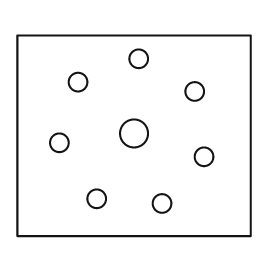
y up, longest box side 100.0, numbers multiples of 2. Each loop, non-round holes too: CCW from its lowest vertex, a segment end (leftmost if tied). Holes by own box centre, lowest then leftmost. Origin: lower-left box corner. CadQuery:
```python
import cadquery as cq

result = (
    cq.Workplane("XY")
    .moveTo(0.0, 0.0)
    .lineTo(100.0, 0.0)
    .lineTo(100.0, 86.0)
    .lineTo(0.0, 86.0)
    .close()
    .moveTo(62.0, 14.0)
    .circle(4.0)
    .moveTo(34.0, 16.0)
    .circle(4.0)
    .moveTo(80.0, 34.0)
    .circle(4.0)
    .moveTo(18.0, 40.0)
    .circle(4.0)
    .moveTo(50.0, 44.0)
    .circle(6.0)
    .moveTo(76.0, 62.0)
    .circle(4.0)
    .moveTo(26.0, 66.0)
    .circle(4.0)
    .moveTo(52.0, 76.0)
    .circle(4.0)
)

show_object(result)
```